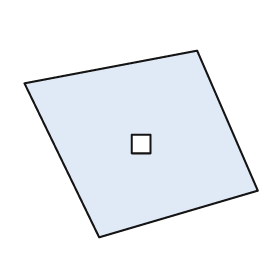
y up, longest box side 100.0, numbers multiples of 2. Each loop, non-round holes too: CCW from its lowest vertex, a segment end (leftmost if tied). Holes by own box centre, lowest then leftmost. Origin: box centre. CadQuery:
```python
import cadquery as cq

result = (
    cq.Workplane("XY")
    .moveTo(-18.0, -40.0)
    .lineTo(50.0, -20.0)
    .lineTo(24.0, 40.0)
    .lineTo(-50.0, 26.0)
    .close()
    .moveTo(-4.0, -4.0)
    .lineTo(4.0, -4.0)
    .lineTo(4.0, 4.0)
    .lineTo(-4.0, 4.0)
    .close()
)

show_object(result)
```